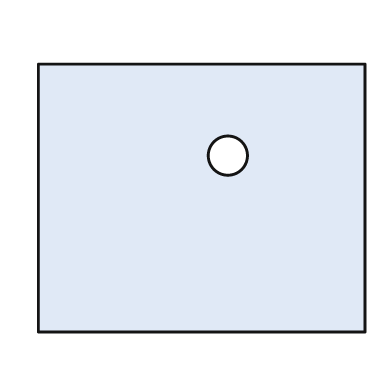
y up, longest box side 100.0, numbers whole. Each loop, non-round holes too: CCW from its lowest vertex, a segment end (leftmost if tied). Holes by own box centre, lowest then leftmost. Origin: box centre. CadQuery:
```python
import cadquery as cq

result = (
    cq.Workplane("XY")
    .moveTo(-50.0, -41.0)
    .lineTo(50.0, -41.0)
    .lineTo(50.0, 41.0)
    .lineTo(-50.0, 41.0)
    .close()
    .moveTo(8.0, 13.0)
    .circle(6.0)
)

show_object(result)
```